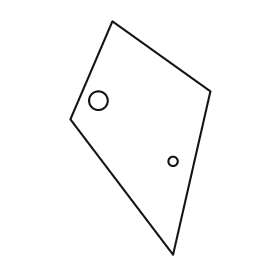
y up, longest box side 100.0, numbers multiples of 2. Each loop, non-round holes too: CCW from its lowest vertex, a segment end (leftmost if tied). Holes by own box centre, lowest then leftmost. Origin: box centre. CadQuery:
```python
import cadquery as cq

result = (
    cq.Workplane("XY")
    .moveTo(14.0, -50.0)
    .lineTo(30.0, 20.0)
    .lineTo(-12.0, 50.0)
    .lineTo(-30.0, 8.0)
    .close()
    .moveTo(14.0, -10.0)
    .circle(2.0)
    .moveTo(-18.0, 16.0)
    .circle(4.0)
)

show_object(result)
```